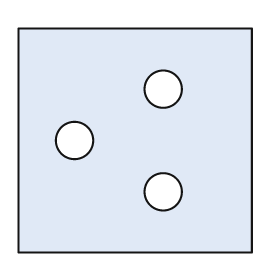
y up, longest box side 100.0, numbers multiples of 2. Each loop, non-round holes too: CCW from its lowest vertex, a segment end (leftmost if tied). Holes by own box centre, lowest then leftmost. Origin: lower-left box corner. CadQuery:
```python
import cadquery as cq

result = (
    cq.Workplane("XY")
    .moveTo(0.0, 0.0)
    .lineTo(100.0, 0.0)
    .lineTo(100.0, 96.0)
    .lineTo(0.0, 96.0)
    .close()
    .moveTo(62.0, 26.0)
    .circle(8.0)
    .moveTo(24.0, 48.0)
    .circle(8.0)
    .moveTo(62.0, 70.0)
    .circle(8.0)
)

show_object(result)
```